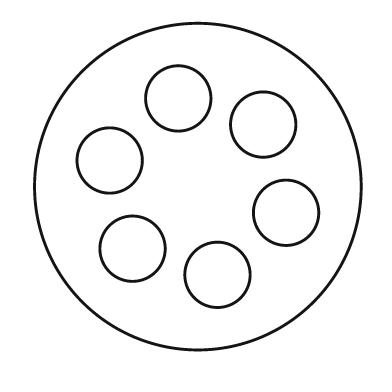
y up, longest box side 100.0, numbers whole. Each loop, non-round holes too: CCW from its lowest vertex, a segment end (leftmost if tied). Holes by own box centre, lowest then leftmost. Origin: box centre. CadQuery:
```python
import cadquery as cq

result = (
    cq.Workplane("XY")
    .moveTo(0.0, 0.0)
    .circle(50.0)
    .moveTo(6.0, -27.0)
    .circle(10.0)
    .moveTo(-20.0, -19.0)
    .circle(10.0)
    .moveTo(27.0, -8.0)
    .circle(10.0)
    .moveTo(-27.0, 8.0)
    .circle(10.0)
    .moveTo(20.0, 19.0)
    .circle(10.0)
    .moveTo(-6.0, 27.0)
    .circle(10.0)
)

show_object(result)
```